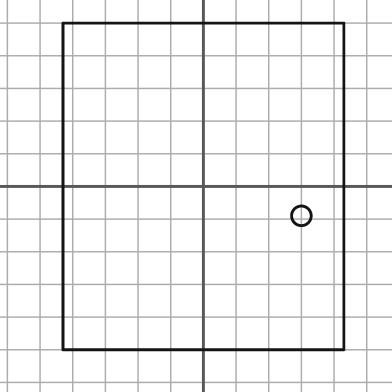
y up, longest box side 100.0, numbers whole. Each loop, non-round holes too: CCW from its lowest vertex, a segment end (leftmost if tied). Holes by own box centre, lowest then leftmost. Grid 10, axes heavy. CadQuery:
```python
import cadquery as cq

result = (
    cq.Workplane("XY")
    .moveTo(-43.0, -50.0)
    .lineTo(43.0, -50.0)
    .lineTo(43.0, 50.0)
    .lineTo(-43.0, 50.0)
    .close()
    .moveTo(30.0, -9.0)
    .circle(3.0)
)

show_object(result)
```